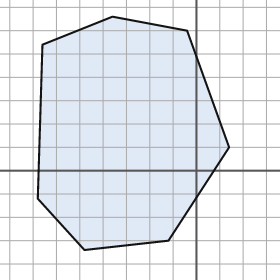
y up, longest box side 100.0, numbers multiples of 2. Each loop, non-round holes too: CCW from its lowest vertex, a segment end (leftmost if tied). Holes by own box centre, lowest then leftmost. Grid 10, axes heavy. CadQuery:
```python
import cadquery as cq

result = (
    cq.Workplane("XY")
    .moveTo(-48.0, -34.0)
    .lineTo(-12.0, -30.0)
    .lineTo(14.0, 10.0)
    .lineTo(-4.0, 60.0)
    .lineTo(-36.0, 66.0)
    .lineTo(-66.0, 54.0)
    .lineTo(-68.0, -12.0)
    .close()
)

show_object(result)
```